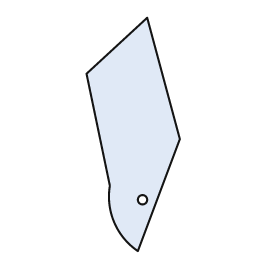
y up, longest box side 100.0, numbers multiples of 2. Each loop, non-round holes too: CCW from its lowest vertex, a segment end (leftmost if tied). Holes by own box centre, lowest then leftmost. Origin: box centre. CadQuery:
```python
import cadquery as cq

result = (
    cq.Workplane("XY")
    .moveTo(2.0, -50.0)
    .lineTo(20.0, -2.0)
    .lineTo(6.0, 50.0)
    .lineTo(-20.0, 26.0)
    .lineTo(-10.0, -22.0)
    .threePointArc((-8.0, -38.0), (2.0, -50.0))
    .close()
    .moveTo(4.0, -28.0)
    .circle(2.0)
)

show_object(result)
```